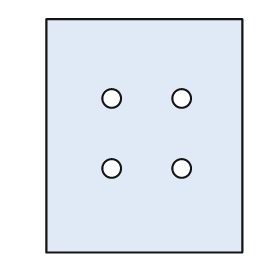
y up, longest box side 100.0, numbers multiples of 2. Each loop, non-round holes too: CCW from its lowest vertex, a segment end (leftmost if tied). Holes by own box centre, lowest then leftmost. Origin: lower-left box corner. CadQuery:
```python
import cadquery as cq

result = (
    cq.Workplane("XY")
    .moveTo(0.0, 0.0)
    .lineTo(84.0, 0.0)
    .lineTo(84.0, 100.0)
    .lineTo(0.0, 100.0)
    .close()
    .moveTo(28.0, 36.0)
    .circle(4.0)
    .moveTo(58.0, 36.0)
    .circle(4.0)
    .moveTo(28.0, 66.0)
    .circle(4.0)
    .moveTo(58.0, 66.0)
    .circle(4.0)
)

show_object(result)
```